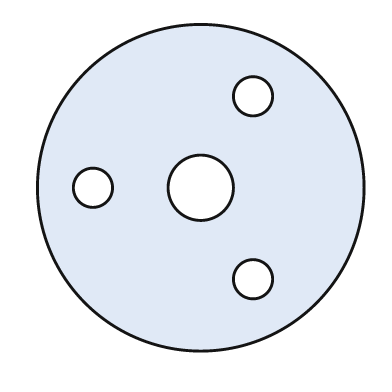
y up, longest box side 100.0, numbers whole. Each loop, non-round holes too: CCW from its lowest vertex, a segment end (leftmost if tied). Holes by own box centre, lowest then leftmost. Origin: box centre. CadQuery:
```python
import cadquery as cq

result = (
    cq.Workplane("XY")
    .moveTo(0.0, 0.0)
    .circle(50.0)
    .moveTo(16.0, -28.0)
    .circle(6.0)
    .moveTo(-33.0, 0.0)
    .circle(6.0)
    .moveTo(0.0, 0.0)
    .circle(10.0)
    .moveTo(16.0, 28.0)
    .circle(6.0)
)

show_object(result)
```